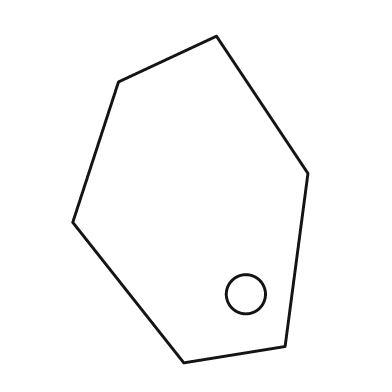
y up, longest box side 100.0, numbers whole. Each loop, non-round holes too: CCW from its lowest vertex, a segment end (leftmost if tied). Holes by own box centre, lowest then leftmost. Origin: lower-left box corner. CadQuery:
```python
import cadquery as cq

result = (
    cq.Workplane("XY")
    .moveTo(34.0, 0.0)
    .lineTo(65.0, 5.0)
    .lineTo(72.0, 58.0)
    .lineTo(44.0, 100.0)
    .lineTo(14.0, 86.0)
    .lineTo(0.0, 43.0)
    .close()
    .moveTo(53.0, 21.0)
    .circle(6.0)
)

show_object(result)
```